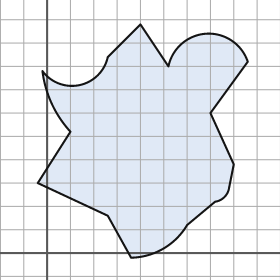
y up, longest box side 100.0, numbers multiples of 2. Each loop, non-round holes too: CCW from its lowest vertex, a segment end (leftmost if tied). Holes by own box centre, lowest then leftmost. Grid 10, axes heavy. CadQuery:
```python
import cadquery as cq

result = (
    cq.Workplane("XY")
    .moveTo(36.0, -2.0)
    .threePointArc((50.0, 2.0), (60.0, 12.0))
    .lineTo(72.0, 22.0)
    .threePointArc((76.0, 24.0), (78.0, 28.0))
    .lineTo(80.0, 38.0)
    .lineTo(70.0, 60.0)
    .lineTo(86.0, 82.0)
    .threePointArc((68.0, 94.0), (52.0, 80.0))
    .lineTo(40.0, 98.0)
    .lineTo(26.0, 84.0)
    .threePointArc((14.0, 72.0), (-2.0, 78.0))
    .threePointArc((2.0, 64.0), (10.0, 52.0))
    .lineTo(-4.0, 30.0)
    .lineTo(26.0, 16.0)
    .close()
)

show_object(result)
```